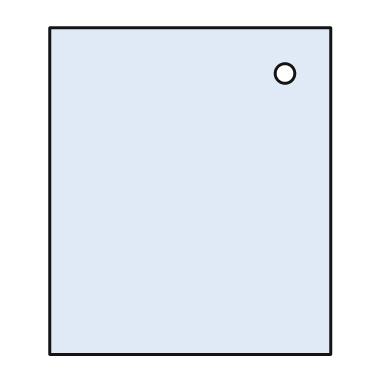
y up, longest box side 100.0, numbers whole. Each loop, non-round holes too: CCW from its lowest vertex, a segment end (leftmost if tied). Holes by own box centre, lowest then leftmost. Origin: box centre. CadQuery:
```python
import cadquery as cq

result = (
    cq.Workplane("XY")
    .moveTo(-43.0, -50.0)
    .lineTo(43.0, -50.0)
    .lineTo(43.0, 50.0)
    .lineTo(-43.0, 50.0)
    .close()
    .moveTo(29.0, 36.0)
    .circle(3.0)
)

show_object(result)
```